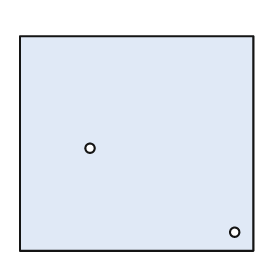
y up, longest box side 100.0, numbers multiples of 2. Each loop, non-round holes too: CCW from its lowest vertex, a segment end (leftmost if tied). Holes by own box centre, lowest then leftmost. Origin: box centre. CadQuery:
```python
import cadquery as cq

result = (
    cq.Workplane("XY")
    .moveTo(-50.0, -46.0)
    .lineTo(50.0, -46.0)
    .lineTo(50.0, 46.0)
    .lineTo(-50.0, 46.0)
    .close()
    .moveTo(42.0, -38.0)
    .circle(2.0)
    .moveTo(-20.0, -2.0)
    .circle(2.0)
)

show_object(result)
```